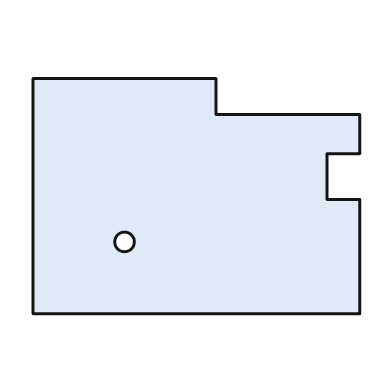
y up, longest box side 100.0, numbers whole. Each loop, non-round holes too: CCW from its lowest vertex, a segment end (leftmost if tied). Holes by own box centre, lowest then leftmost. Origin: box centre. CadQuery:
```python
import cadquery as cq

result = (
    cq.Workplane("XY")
    .moveTo(-50.0, -36.0)
    .lineTo(50.0, -36.0)
    .lineTo(50.0, -1.0)
    .lineTo(40.0, -1.0)
    .lineTo(40.0, 13.0)
    .lineTo(50.0, 13.0)
    .lineTo(50.0, 25.0)
    .lineTo(6.0, 25.0)
    .lineTo(6.0, 36.0)
    .lineTo(-50.0, 36.0)
    .close()
    .moveTo(-22.0, -14.0)
    .circle(3.0)
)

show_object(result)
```